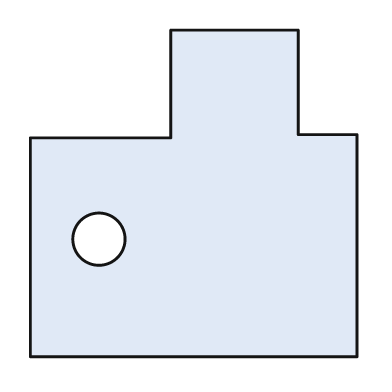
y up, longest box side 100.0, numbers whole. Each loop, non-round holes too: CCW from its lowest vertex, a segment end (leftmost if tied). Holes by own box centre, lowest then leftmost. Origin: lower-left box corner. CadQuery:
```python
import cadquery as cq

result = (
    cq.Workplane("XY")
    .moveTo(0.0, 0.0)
    .lineTo(100.0, 0.0)
    .lineTo(100.0, 68.0)
    .lineTo(82.0, 68.0)
    .lineTo(82.0, 100.0)
    .lineTo(43.0, 100.0)
    .lineTo(43.0, 67.0)
    .lineTo(0.0, 67.0)
    .close()
    .moveTo(21.0, 36.0)
    .circle(8.0)
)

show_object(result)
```